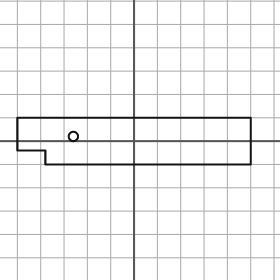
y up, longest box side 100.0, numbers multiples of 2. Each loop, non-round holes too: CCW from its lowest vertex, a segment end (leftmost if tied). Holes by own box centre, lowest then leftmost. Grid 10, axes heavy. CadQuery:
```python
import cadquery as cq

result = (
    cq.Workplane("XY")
    .moveTo(-38.0, -10.0)
    .lineTo(50.0, -10.0)
    .lineTo(50.0, 10.0)
    .lineTo(-50.0, 10.0)
    .lineTo(-50.0, -4.0)
    .lineTo(-38.0, -4.0)
    .close()
    .moveTo(-26.0, 2.0)
    .circle(2.0)
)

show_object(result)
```